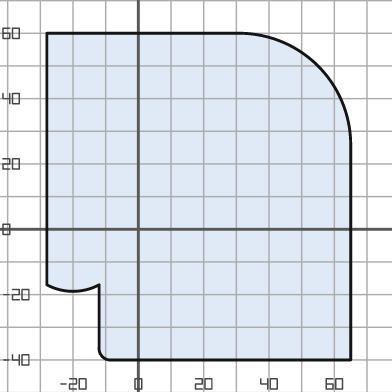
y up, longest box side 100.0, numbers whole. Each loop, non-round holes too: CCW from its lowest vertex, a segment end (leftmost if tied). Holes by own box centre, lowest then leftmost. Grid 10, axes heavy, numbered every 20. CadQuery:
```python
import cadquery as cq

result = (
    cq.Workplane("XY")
    .moveTo(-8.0, -40.0)
    .lineTo(65.0, -40.0)
    .lineTo(65.0, 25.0)
    .threePointArc((55.0, 50.0), (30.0, 60.0))
    .lineTo(-28.0, 60.0)
    .lineTo(-28.0, -17.0)
    .threePointArc((-20.0, -19.0), (-12.0, -17.0))
    .lineTo(-12.0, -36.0)
    .threePointArc((-11.0, -39.0), (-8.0, -40.0))
    .close()
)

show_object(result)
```